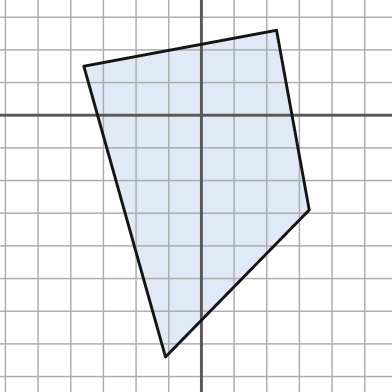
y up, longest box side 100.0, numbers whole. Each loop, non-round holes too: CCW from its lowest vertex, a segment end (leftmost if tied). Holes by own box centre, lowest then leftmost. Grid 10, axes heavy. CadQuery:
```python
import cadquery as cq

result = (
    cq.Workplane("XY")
    .moveTo(-11.0, -74.0)
    .lineTo(33.0, -29.0)
    .lineTo(23.0, 26.0)
    .lineTo(-36.0, 15.0)
    .close()
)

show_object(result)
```